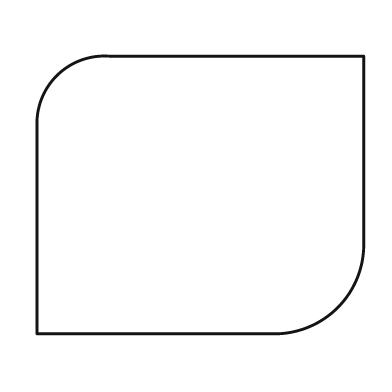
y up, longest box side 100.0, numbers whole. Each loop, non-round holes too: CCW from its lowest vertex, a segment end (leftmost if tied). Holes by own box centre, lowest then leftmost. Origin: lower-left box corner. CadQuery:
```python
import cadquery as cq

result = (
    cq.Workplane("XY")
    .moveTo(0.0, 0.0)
    .lineTo(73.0, 0.0)
    .threePointArc((92.0, 8.0), (100.0, 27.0))
    .lineTo(100.0, 85.0)
    .lineTo(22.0, 85.0)
    .threePointArc((6.0, 79.0), (0.0, 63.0))
    .close()
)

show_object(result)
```